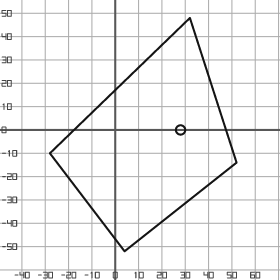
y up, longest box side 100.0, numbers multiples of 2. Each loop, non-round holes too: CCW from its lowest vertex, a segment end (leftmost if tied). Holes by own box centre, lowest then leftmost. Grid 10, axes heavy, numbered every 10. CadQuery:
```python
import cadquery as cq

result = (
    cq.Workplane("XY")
    .moveTo(4.0, -52.0)
    .lineTo(52.0, -14.0)
    .lineTo(32.0, 48.0)
    .lineTo(-28.0, -10.0)
    .close()
    .moveTo(28.0, 0.0)
    .circle(2.0)
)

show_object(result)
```